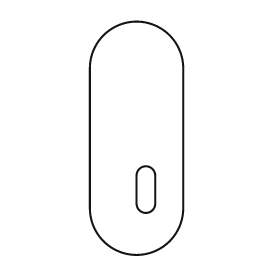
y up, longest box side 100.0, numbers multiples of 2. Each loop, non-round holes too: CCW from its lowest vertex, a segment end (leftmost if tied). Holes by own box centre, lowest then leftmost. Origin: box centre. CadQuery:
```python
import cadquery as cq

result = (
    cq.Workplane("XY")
    .moveTo(-20.0, -30.0)
    .threePointArc((0.0, -50.0), (20.0, -30.0))
    .lineTo(20.0, 30.0)
    .threePointArc((0.0, 50.0), (-20.0, 30.0))
    .close()
    .moveTo(0.0, -28.0)
    .threePointArc((4.0, -32.0), (8.0, -28.0))
    .lineTo(8.0, -16.0)
    .threePointArc((4.0, -12.0), (0.0, -16.0))
    .close()
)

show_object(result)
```